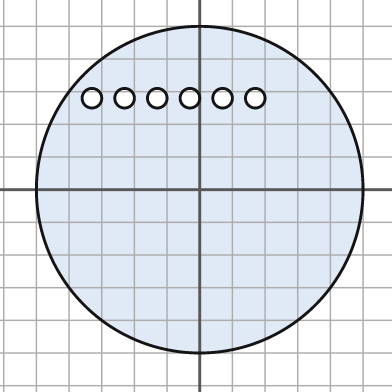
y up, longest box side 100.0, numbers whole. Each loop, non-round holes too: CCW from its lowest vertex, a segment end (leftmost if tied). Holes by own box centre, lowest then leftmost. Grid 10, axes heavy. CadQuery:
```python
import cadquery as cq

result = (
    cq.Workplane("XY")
    .moveTo(0.0, 0.0)
    .circle(50.0)
    .moveTo(-33.0, 28.0)
    .circle(3.0)
    .moveTo(-23.0, 28.0)
    .circle(3.0)
    .moveTo(-13.0, 28.0)
    .circle(3.0)
    .moveTo(-3.0, 28.0)
    .circle(3.0)
    .moveTo(7.0, 28.0)
    .circle(3.0)
    .moveTo(17.0, 28.0)
    .circle(3.0)
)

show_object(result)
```